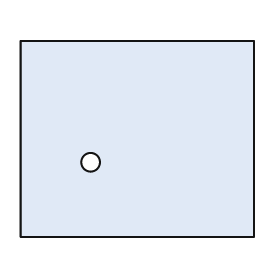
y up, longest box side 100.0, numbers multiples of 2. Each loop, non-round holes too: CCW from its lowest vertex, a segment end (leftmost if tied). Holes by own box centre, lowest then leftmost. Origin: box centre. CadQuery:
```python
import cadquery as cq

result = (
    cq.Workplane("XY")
    .moveTo(-50.0, -42.0)
    .lineTo(50.0, -42.0)
    .lineTo(50.0, 42.0)
    .lineTo(-50.0, 42.0)
    .close()
    .moveTo(-20.0, -10.0)
    .circle(4.0)
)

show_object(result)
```